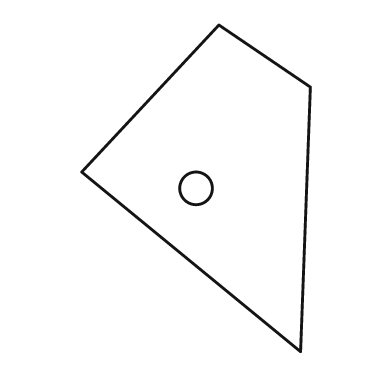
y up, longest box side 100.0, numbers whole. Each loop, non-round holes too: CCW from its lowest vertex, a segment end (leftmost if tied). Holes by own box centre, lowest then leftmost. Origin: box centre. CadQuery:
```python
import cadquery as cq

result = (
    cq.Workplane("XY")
    .moveTo(32.0, -50.0)
    .lineTo(35.0, 31.0)
    .lineTo(7.0, 50.0)
    .lineTo(-35.0, 5.0)
    .close()
    .moveTo(0.0, 0.0)
    .circle(5.0)
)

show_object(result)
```